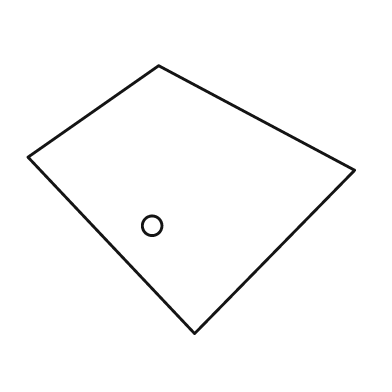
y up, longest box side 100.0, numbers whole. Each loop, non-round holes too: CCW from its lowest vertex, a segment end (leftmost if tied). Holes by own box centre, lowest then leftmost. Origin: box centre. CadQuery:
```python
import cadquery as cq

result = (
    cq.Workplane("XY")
    .moveTo(1.0, -41.0)
    .lineTo(50.0, 9.0)
    .lineTo(-10.0, 41.0)
    .lineTo(-50.0, 13.0)
    .close()
    .moveTo(-12.0, -8.0)
    .circle(3.0)
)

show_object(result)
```